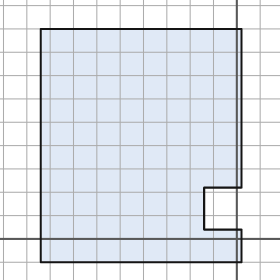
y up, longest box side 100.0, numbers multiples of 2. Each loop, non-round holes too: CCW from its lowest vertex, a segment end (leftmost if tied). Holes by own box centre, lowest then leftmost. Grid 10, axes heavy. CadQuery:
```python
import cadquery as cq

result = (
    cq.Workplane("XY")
    .moveTo(-84.0, -10.0)
    .lineTo(2.0, -10.0)
    .lineTo(2.0, 4.0)
    .lineTo(-14.0, 4.0)
    .lineTo(-14.0, 22.0)
    .lineTo(2.0, 22.0)
    .lineTo(2.0, 90.0)
    .lineTo(-84.0, 90.0)
    .close()
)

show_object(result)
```